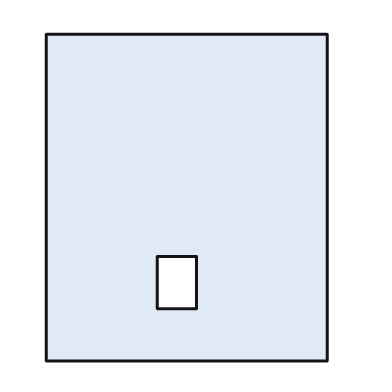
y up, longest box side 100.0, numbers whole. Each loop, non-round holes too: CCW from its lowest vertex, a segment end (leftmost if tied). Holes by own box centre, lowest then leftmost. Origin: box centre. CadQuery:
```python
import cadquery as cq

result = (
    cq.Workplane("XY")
    .moveTo(-43.0, -50.0)
    .lineTo(43.0, -50.0)
    .lineTo(43.0, 50.0)
    .lineTo(-43.0, 50.0)
    .close()
    .moveTo(-9.0, -34.0)
    .lineTo(3.0, -34.0)
    .lineTo(3.0, -18.0)
    .lineTo(-9.0, -18.0)
    .close()
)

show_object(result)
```